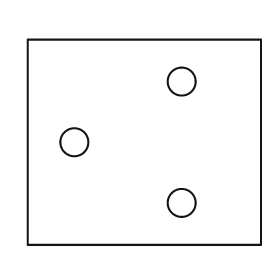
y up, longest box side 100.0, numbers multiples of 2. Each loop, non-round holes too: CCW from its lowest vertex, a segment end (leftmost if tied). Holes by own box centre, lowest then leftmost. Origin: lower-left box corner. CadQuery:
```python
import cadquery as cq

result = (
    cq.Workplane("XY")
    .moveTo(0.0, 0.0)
    .lineTo(100.0, 0.0)
    .lineTo(100.0, 88.0)
    .lineTo(0.0, 88.0)
    .close()
    .moveTo(66.0, 18.0)
    .circle(6.0)
    .moveTo(20.0, 44.0)
    .circle(6.0)
    .moveTo(66.0, 70.0)
    .circle(6.0)
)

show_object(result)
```